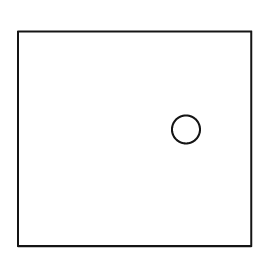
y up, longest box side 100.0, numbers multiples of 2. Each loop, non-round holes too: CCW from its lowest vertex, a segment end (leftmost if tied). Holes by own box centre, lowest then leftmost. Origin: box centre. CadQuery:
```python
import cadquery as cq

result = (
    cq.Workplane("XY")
    .moveTo(-50.0, -46.0)
    .lineTo(50.0, -46.0)
    .lineTo(50.0, 46.0)
    .lineTo(-50.0, 46.0)
    .close()
    .moveTo(22.0, 4.0)
    .circle(6.0)
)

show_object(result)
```